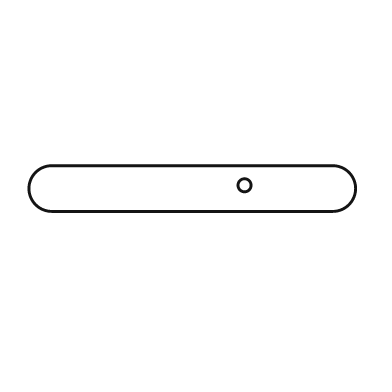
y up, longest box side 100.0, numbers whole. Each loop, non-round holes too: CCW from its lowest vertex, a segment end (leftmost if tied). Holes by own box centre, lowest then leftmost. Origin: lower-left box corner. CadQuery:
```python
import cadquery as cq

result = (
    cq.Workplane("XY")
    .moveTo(7.0, 0.0)
    .lineTo(93.0, 0.0)
    .threePointArc((100.0, 7.0), (93.0, 14.0))
    .lineTo(7.0, 14.0)
    .threePointArc((0.0, 7.0), (7.0, 0.0))
    .close()
    .moveTo(66.0, 8.0)
    .circle(2.0)
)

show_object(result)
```